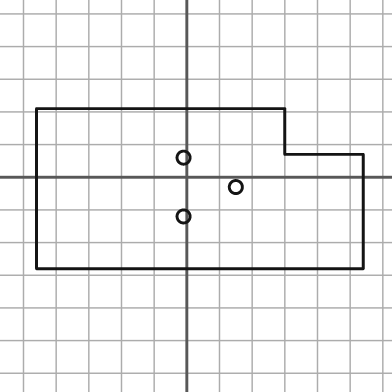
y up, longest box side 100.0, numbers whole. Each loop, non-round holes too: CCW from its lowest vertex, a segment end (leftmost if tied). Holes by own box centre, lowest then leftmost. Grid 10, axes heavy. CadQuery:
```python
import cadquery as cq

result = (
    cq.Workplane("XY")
    .moveTo(-46.0, -28.0)
    .lineTo(54.0, -28.0)
    .lineTo(54.0, 7.0)
    .lineTo(30.0, 7.0)
    .lineTo(30.0, 21.0)
    .lineTo(-46.0, 21.0)
    .close()
    .moveTo(-1.0, -12.0)
    .circle(2.0)
    .moveTo(15.0, -3.0)
    .circle(2.0)
    .moveTo(-1.0, 6.0)
    .circle(2.0)
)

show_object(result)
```